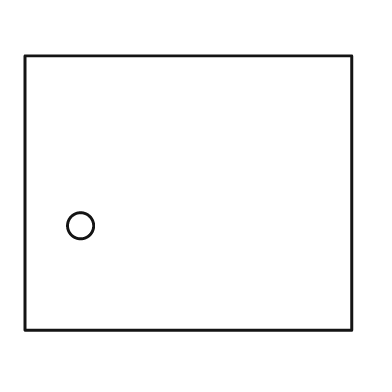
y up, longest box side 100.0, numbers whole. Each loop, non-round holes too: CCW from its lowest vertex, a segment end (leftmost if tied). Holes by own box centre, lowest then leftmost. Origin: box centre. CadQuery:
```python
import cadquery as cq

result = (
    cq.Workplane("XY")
    .moveTo(-50.0, -42.0)
    .lineTo(50.0, -42.0)
    .lineTo(50.0, 42.0)
    .lineTo(-50.0, 42.0)
    .close()
    .moveTo(-33.0, -10.0)
    .circle(4.0)
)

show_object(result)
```